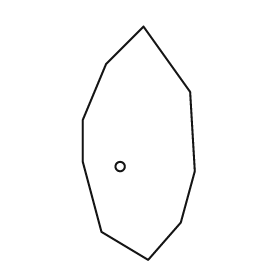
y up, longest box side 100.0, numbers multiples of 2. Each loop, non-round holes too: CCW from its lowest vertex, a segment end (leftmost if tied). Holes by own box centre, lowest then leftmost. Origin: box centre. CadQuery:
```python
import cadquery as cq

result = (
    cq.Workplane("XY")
    .moveTo(4.0, -50.0)
    .lineTo(18.0, -34.0)
    .lineTo(24.0, -12.0)
    .lineTo(22.0, 22.0)
    .lineTo(2.0, 50.0)
    .lineTo(-14.0, 34.0)
    .lineTo(-24.0, 10.0)
    .lineTo(-24.0, -8.0)
    .lineTo(-16.0, -38.0)
    .close()
    .moveTo(-8.0, -10.0)
    .circle(2.0)
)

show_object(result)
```